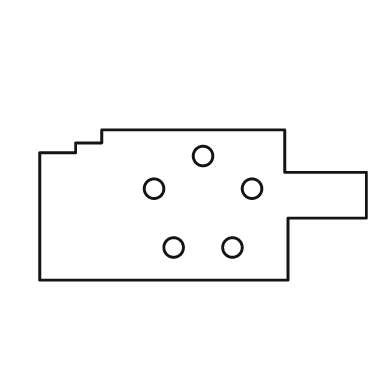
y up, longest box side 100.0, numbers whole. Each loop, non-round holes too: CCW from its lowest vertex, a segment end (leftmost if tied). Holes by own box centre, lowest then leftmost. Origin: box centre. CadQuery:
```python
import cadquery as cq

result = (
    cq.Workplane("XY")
    .moveTo(-50.0, -23.0)
    .lineTo(26.0, -23.0)
    .lineTo(26.0, -4.0)
    .lineTo(50.0, -4.0)
    .lineTo(50.0, 10.0)
    .lineTo(25.0, 10.0)
    .lineTo(25.0, 23.0)
    .lineTo(-31.0, 23.0)
    .lineTo(-31.0, 19.0)
    .lineTo(-39.0, 19.0)
    .lineTo(-39.0, 16.0)
    .lineTo(-50.0, 16.0)
    .close()
    .moveTo(-9.0, -13.0)
    .circle(3.0)
    .moveTo(9.0, -13.0)
    .circle(3.0)
    .moveTo(-15.0, 5.0)
    .circle(3.0)
    .moveTo(15.0, 5.0)
    .circle(3.0)
    .moveTo(0.0, 15.0)
    .circle(3.0)
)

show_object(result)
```